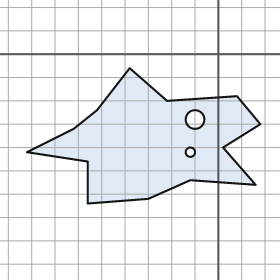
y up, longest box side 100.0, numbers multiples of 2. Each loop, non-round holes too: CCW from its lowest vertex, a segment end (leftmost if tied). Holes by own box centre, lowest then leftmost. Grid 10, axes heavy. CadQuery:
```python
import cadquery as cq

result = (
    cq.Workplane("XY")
    .moveTo(-56.0, -64.0)
    .lineTo(-30.0, -62.0)
    .lineTo(-12.0, -54.0)
    .lineTo(16.0, -56.0)
    .lineTo(2.0, -40.0)
    .lineTo(18.0, -30.0)
    .lineTo(8.0, -18.0)
    .lineTo(-22.0, -20.0)
    .lineTo(-38.0, -6.0)
    .lineTo(-52.0, -24.0)
    .lineTo(-62.0, -32.0)
    .lineTo(-82.0, -42.0)
    .lineTo(-56.0, -46.0)
    .close()
    .moveTo(-12.0, -42.0)
    .circle(2.0)
    .moveTo(-10.0, -28.0)
    .circle(4.0)
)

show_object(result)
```